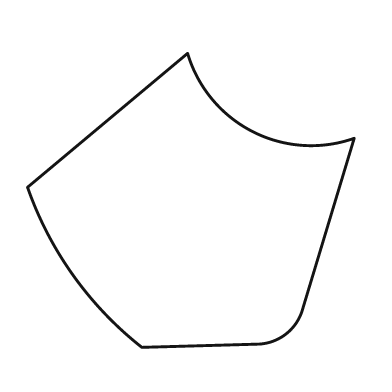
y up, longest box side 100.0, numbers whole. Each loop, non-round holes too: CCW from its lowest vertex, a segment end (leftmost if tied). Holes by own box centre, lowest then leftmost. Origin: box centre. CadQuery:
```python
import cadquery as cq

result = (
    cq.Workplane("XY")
    .moveTo(-15.0, -45.0)
    .lineTo(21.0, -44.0)
    .threePointArc((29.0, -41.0), (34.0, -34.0))
    .lineTo(50.0, 19.0)
    .threePointArc((19.0, 21.0), (-1.0, 45.0))
    .lineTo(-50.0, 4.0)
    .threePointArc((-36.0, -23.0), (-15.0, -45.0))
    .close()
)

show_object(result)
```